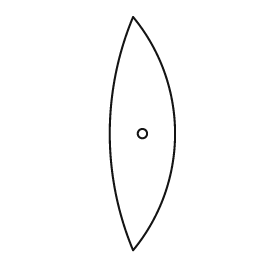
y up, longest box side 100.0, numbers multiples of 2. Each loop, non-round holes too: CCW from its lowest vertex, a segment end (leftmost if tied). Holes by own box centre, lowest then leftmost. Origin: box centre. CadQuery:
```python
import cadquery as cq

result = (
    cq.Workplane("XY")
    .moveTo(-4.0, -50.0)
    .threePointArc((14.0, 0.0), (-4.0, 50.0))
    .threePointArc((-14.0, 0.0), (-4.0, -50.0))
    .close()
    .moveTo(0.0, 0.0)
    .circle(2.0)
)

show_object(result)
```